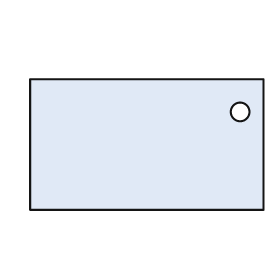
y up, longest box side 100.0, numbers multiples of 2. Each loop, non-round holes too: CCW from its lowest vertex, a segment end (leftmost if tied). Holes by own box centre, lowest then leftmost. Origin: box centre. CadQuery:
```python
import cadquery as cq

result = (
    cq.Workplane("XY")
    .moveTo(-50.0, -28.0)
    .lineTo(50.0, -28.0)
    .lineTo(50.0, 28.0)
    .lineTo(-50.0, 28.0)
    .close()
    .moveTo(40.0, 14.0)
    .circle(4.0)
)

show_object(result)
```